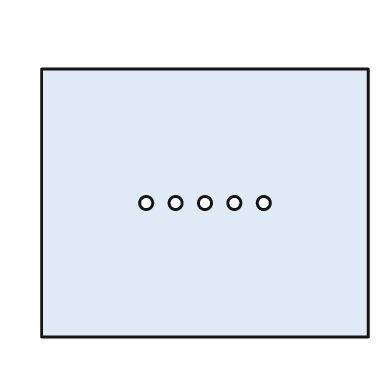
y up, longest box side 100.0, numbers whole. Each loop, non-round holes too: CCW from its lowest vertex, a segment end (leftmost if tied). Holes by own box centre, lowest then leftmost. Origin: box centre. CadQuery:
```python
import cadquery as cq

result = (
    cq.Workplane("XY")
    .moveTo(-50.0, -41.0)
    .lineTo(50.0, -41.0)
    .lineTo(50.0, 41.0)
    .lineTo(-50.0, 41.0)
    .close()
    .moveTo(-18.0, 0.0)
    .circle(2.0)
    .moveTo(-9.0, 0.0)
    .circle(2.0)
    .moveTo(0.0, 0.0)
    .circle(2.0)
    .moveTo(9.0, 0.0)
    .circle(2.0)
    .moveTo(18.0, 0.0)
    .circle(2.0)
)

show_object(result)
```